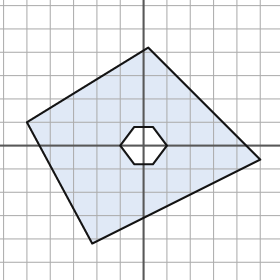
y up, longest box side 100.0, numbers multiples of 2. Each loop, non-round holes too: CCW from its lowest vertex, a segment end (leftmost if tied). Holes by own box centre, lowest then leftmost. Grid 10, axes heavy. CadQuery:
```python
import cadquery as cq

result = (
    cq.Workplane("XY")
    .moveTo(-22.0, -42.0)
    .lineTo(50.0, -6.0)
    .lineTo(2.0, 42.0)
    .lineTo(-50.0, 10.0)
    .close()
    .moveTo(-4.0, -8.0)
    .lineTo(4.0, -8.0)
    .lineTo(10.0, 0.0)
    .lineTo(4.0, 8.0)
    .lineTo(-4.0, 8.0)
    .lineTo(-10.0, 0.0)
    .close()
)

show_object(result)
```